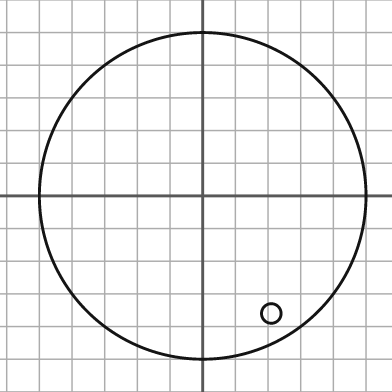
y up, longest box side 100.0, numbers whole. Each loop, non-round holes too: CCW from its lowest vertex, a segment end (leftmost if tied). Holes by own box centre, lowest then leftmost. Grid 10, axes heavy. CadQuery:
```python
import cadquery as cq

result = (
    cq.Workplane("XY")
    .moveTo(0.0, 0.0)
    .circle(50.0)
    .moveTo(21.0, -36.0)
    .circle(3.0)
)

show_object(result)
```